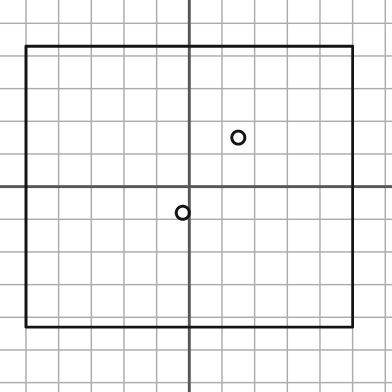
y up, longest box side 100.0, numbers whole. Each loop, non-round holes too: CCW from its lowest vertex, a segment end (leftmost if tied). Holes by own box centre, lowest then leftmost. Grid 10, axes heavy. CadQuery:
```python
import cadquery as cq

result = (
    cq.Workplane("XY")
    .moveTo(-50.0, -43.0)
    .lineTo(50.0, -43.0)
    .lineTo(50.0, 43.0)
    .lineTo(-50.0, 43.0)
    .close()
    .moveTo(-2.0, -8.0)
    .circle(2.0)
    .moveTo(15.0, 15.0)
    .circle(2.0)
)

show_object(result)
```